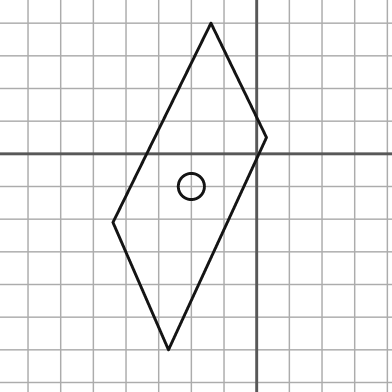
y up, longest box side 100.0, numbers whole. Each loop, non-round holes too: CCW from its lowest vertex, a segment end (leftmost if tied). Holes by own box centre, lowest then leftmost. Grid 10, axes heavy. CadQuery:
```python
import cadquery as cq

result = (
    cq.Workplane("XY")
    .moveTo(-27.0, -60.0)
    .lineTo(3.0, 5.0)
    .lineTo(-14.0, 40.0)
    .lineTo(-44.0, -21.0)
    .close()
    .moveTo(-20.0, -10.0)
    .circle(4.0)
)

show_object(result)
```